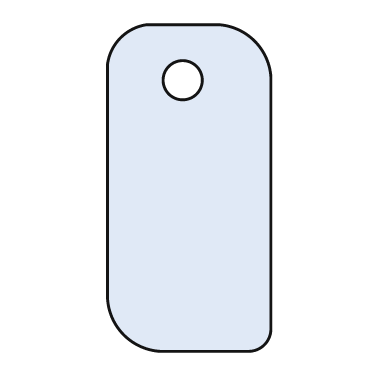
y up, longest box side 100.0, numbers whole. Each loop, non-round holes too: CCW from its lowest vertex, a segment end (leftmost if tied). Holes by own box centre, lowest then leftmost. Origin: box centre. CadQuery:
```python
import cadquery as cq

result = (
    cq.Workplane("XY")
    .moveTo(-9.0, -50.0)
    .lineTo(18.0, -50.0)
    .threePointArc((23.0, -48.0), (25.0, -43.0))
    .lineTo(25.0, 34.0)
    .threePointArc((20.0, 45.0), (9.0, 50.0))
    .lineTo(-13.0, 50.0)
    .threePointArc((-21.0, 46.0), (-25.0, 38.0))
    .lineTo(-25.0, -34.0)
    .threePointArc((-20.0, -45.0), (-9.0, -50.0))
    .close()
    .moveTo(-2.0, 33.0)
    .circle(6.0)
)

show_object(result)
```